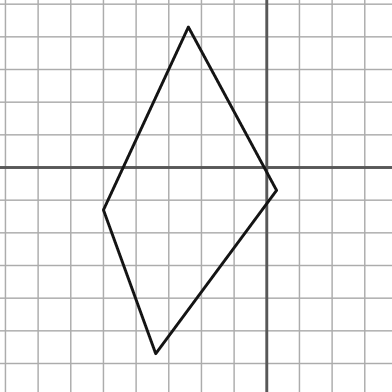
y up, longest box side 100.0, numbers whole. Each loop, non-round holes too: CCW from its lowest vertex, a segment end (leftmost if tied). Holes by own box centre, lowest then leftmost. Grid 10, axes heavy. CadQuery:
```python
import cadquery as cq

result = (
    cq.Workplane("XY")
    .moveTo(-34.0, -57.0)
    .lineTo(3.0, -7.0)
    .lineTo(-24.0, 43.0)
    .lineTo(-50.0, -13.0)
    .close()
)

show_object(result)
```